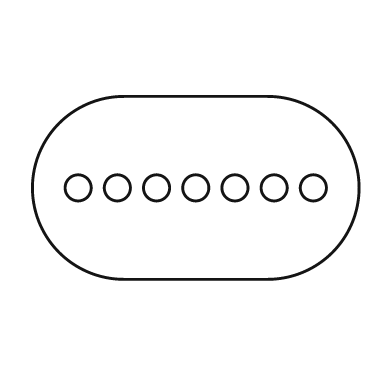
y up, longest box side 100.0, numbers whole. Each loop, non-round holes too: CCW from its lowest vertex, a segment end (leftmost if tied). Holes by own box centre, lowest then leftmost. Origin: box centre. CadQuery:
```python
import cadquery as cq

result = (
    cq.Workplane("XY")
    .moveTo(-22.0, -28.0)
    .lineTo(22.0, -28.0)
    .threePointArc((50.0, 0.0), (22.0, 28.0))
    .lineTo(-22.0, 28.0)
    .threePointArc((-50.0, 0.0), (-22.0, -28.0))
    .close()
    .moveTo(-36.0, 0.0)
    .circle(4.0)
    .moveTo(-24.0, 0.0)
    .circle(4.0)
    .moveTo(-12.0, 0.0)
    .circle(4.0)
    .moveTo(0.0, 0.0)
    .circle(4.0)
    .moveTo(12.0, 0.0)
    .circle(4.0)
    .moveTo(24.0, 0.0)
    .circle(4.0)
    .moveTo(36.0, 0.0)
    .circle(4.0)
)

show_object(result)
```